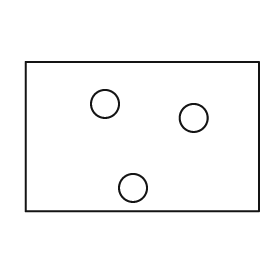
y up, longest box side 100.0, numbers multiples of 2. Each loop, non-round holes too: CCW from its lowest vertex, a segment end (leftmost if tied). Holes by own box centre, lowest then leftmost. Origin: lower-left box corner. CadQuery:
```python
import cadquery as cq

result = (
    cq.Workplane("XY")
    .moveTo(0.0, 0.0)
    .lineTo(100.0, 0.0)
    .lineTo(100.0, 64.0)
    .lineTo(0.0, 64.0)
    .close()
    .moveTo(46.0, 10.0)
    .circle(6.0)
    .moveTo(72.0, 40.0)
    .circle(6.0)
    .moveTo(34.0, 46.0)
    .circle(6.0)
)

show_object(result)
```